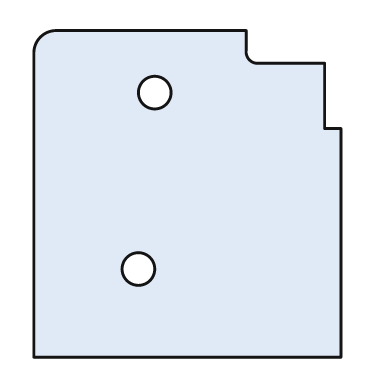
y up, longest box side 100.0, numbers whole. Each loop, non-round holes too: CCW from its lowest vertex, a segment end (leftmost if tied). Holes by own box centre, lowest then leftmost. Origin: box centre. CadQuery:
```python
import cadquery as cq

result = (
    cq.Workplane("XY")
    .moveTo(-47.0, -50.0)
    .lineTo(47.0, -50.0)
    .lineTo(47.0, 20.0)
    .lineTo(42.0, 20.0)
    .lineTo(42.0, 40.0)
    .lineTo(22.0, 40.0)
    .threePointArc((19.0, 41.0), (18.0, 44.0))
    .lineTo(18.0, 50.0)
    .lineTo(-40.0, 50.0)
    .threePointArc((-45.0, 48.0), (-47.0, 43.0))
    .close()
    .moveTo(-15.0, -23.0)
    .circle(5.0)
    .moveTo(-10.0, 31.0)
    .circle(5.0)
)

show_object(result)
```